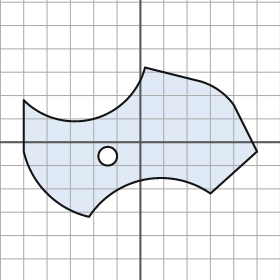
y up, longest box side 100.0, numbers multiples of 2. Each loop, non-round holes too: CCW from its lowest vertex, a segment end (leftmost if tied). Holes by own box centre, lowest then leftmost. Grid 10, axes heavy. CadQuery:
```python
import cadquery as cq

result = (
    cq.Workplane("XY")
    .moveTo(-22.0, -32.0)
    .threePointArc((2.0, -16.0), (30.0, -22.0))
    .lineTo(50.0, -4.0)
    .lineTo(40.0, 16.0)
    .threePointArc((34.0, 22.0), (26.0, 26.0))
    .lineTo(2.0, 32.0)
    .threePointArc((-20.0, 10.0), (-50.0, 18.0))
    .lineTo(-50.0, -4.0)
    .threePointArc((-40.0, -22.0), (-22.0, -32.0))
    .close()
    .moveTo(-14.0, -6.0)
    .circle(4.0)
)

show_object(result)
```